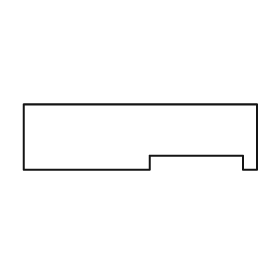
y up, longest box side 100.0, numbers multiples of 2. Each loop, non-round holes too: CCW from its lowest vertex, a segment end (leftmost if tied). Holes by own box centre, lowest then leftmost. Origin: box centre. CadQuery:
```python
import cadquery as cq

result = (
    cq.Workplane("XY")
    .moveTo(-50.0, -14.0)
    .lineTo(4.0, -14.0)
    .lineTo(4.0, -8.0)
    .lineTo(44.0, -8.0)
    .lineTo(44.0, -14.0)
    .lineTo(50.0, -14.0)
    .lineTo(50.0, 14.0)
    .lineTo(-50.0, 14.0)
    .close()
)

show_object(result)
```